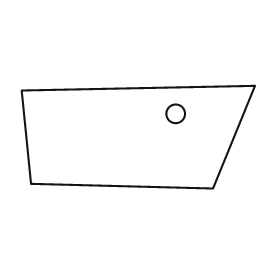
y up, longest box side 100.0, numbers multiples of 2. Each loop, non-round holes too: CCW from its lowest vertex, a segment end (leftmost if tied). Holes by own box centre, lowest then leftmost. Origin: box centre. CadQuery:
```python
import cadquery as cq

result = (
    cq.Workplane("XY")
    .moveTo(32.0, -22.0)
    .lineTo(50.0, 22.0)
    .lineTo(-50.0, 20.0)
    .lineTo(-46.0, -20.0)
    .close()
    .moveTo(16.0, 10.0)
    .circle(4.0)
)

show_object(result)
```